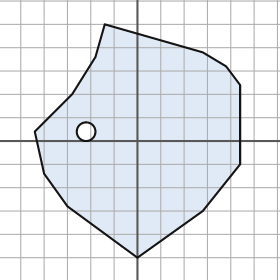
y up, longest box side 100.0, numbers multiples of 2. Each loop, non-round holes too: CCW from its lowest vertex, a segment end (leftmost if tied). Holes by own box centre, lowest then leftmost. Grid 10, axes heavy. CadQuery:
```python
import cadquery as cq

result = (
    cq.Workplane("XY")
    .moveTo(0.0, -50.0)
    .lineTo(28.0, -30.0)
    .lineTo(44.0, -10.0)
    .lineTo(44.0, 24.0)
    .lineTo(38.0, 32.0)
    .lineTo(28.0, 38.0)
    .lineTo(-14.0, 50.0)
    .lineTo(-18.0, 36.0)
    .lineTo(-28.0, 20.0)
    .lineTo(-44.0, 4.0)
    .lineTo(-40.0, -14.0)
    .lineTo(-30.0, -28.0)
    .close()
    .moveTo(-22.0, 4.0)
    .circle(4.0)
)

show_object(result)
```